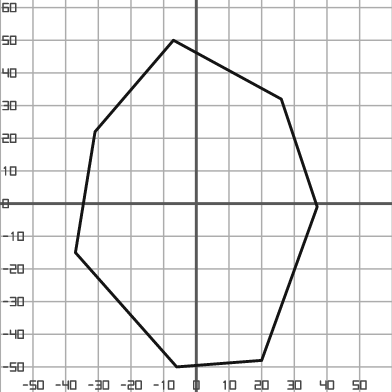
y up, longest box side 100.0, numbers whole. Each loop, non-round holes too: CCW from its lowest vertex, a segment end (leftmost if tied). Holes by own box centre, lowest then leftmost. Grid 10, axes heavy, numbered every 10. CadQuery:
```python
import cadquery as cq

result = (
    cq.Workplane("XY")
    .moveTo(-6.0, -50.0)
    .lineTo(20.0, -48.0)
    .lineTo(37.0, -1.0)
    .lineTo(26.0, 32.0)
    .lineTo(-7.0, 50.0)
    .lineTo(-31.0, 22.0)
    .lineTo(-37.0, -15.0)
    .close()
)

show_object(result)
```